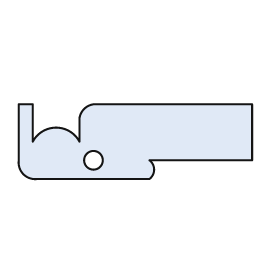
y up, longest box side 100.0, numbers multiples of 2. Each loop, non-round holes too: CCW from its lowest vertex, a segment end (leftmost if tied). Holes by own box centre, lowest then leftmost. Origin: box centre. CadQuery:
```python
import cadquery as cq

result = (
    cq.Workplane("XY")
    .moveTo(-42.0, -16.0)
    .lineTo(6.0, -16.0)
    .threePointArc((8.0, -12.0), (6.0, -8.0))
    .lineTo(50.0, -8.0)
    .lineTo(50.0, 16.0)
    .lineTo(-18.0, 16.0)
    .threePointArc((-22.0, 14.0), (-24.0, 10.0))
    .lineTo(-24.0, 0.0)
    .threePointArc((-34.0, 6.0), (-44.0, 0.0))
    .lineTo(-44.0, 16.0)
    .lineTo(-50.0, 16.0)
    .lineTo(-50.0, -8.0)
    .threePointArc((-48.0, -14.0), (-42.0, -16.0))
    .close()
    .moveTo(-18.0, -8.0)
    .circle(4.0)
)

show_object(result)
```